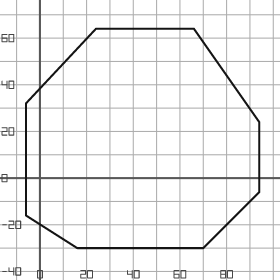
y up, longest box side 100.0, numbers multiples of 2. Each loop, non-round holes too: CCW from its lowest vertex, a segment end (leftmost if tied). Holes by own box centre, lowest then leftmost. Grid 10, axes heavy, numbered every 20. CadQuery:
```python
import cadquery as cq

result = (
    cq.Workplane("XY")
    .moveTo(16.0, -30.0)
    .lineTo(70.0, -30.0)
    .lineTo(94.0, -6.0)
    .lineTo(94.0, 24.0)
    .lineTo(66.0, 64.0)
    .lineTo(24.0, 64.0)
    .lineTo(-6.0, 32.0)
    .lineTo(-6.0, -16.0)
    .close()
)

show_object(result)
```